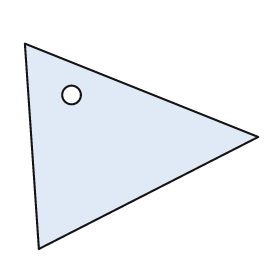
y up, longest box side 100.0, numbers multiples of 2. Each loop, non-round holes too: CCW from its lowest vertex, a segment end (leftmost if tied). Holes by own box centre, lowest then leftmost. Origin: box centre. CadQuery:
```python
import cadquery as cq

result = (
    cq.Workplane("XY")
    .moveTo(-44.0, -44.0)
    .lineTo(50.0, 4.0)
    .lineTo(-50.0, 44.0)
    .close()
    .moveTo(-30.0, 22.0)
    .circle(4.0)
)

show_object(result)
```